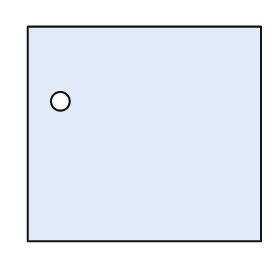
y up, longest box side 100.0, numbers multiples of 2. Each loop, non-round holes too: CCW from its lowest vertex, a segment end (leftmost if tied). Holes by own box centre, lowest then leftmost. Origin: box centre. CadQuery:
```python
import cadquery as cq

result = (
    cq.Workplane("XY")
    .moveTo(-50.0, -46.0)
    .lineTo(50.0, -46.0)
    .lineTo(50.0, 46.0)
    .lineTo(-50.0, 46.0)
    .close()
    .moveTo(-36.0, 14.0)
    .circle(4.0)
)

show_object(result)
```